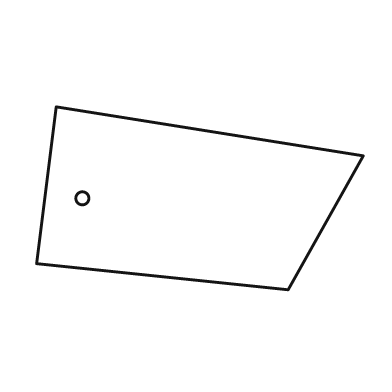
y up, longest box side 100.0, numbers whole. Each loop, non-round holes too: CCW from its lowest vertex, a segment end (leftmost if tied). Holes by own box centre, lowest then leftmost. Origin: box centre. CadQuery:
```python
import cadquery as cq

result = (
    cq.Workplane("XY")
    .moveTo(27.0, -28.0)
    .lineTo(50.0, 13.0)
    .lineTo(-44.0, 28.0)
    .lineTo(-50.0, -20.0)
    .close()
    .moveTo(-36.0, 0.0)
    .circle(2.0)
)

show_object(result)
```